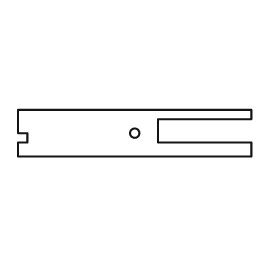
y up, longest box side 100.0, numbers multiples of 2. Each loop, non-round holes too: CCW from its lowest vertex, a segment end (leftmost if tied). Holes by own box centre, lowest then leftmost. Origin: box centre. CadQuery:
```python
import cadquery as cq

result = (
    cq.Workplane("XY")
    .moveTo(-50.0, -10.0)
    .lineTo(50.0, -10.0)
    .lineTo(50.0, -4.0)
    .lineTo(10.0, -4.0)
    .lineTo(10.0, 6.0)
    .lineTo(50.0, 6.0)
    .lineTo(50.0, 10.0)
    .lineTo(-50.0, 10.0)
    .lineTo(-50.0, 0.0)
    .lineTo(-46.0, 0.0)
    .lineTo(-46.0, -4.0)
    .lineTo(-50.0, -4.0)
    .close()
    .moveTo(0.0, 0.0)
    .circle(2.0)
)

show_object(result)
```